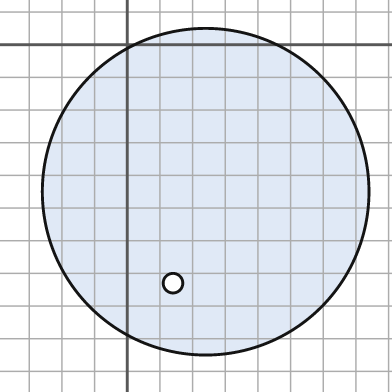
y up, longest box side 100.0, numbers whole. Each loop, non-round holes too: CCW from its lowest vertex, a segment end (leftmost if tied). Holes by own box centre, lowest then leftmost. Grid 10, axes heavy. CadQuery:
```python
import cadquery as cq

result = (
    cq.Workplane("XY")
    .moveTo(24.0, -45.0)
    .circle(50.0)
    .moveTo(14.0, -73.0)
    .circle(3.0)
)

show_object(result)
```